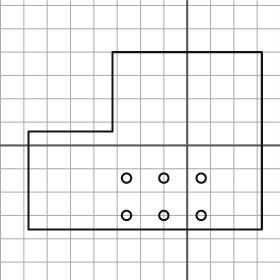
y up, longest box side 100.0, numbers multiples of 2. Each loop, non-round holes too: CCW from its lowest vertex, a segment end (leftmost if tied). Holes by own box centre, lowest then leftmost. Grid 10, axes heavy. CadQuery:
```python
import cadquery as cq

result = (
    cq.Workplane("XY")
    .moveTo(-68.0, -36.0)
    .lineTo(32.0, -36.0)
    .lineTo(32.0, 40.0)
    .lineTo(-32.0, 40.0)
    .lineTo(-32.0, 6.0)
    .lineTo(-68.0, 6.0)
    .close()
    .moveTo(-26.0, -30.0)
    .circle(2.0)
    .moveTo(-10.0, -30.0)
    .circle(2.0)
    .moveTo(6.0, -30.0)
    .circle(2.0)
    .moveTo(-26.0, -14.0)
    .circle(2.0)
    .moveTo(-10.0, -14.0)
    .circle(2.0)
    .moveTo(6.0, -14.0)
    .circle(2.0)
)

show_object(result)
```